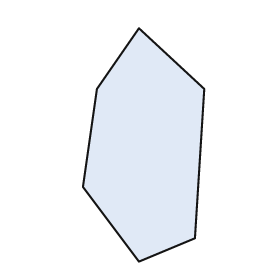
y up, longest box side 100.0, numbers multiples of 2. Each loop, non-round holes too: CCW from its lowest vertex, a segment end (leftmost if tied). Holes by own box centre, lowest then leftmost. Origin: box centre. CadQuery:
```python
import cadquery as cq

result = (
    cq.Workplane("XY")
    .moveTo(-2.0, -50.0)
    .lineTo(22.0, -40.0)
    .lineTo(26.0, 24.0)
    .lineTo(-2.0, 50.0)
    .lineTo(-20.0, 24.0)
    .lineTo(-26.0, -18.0)
    .close()
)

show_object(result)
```